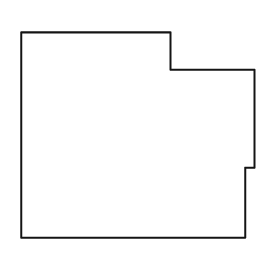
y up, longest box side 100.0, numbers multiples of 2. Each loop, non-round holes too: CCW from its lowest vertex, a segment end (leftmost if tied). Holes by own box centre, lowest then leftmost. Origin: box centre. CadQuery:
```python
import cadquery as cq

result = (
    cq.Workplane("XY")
    .moveTo(-50.0, -44.0)
    .lineTo(46.0, -44.0)
    .lineTo(46.0, -14.0)
    .lineTo(50.0, -14.0)
    .lineTo(50.0, 28.0)
    .lineTo(14.0, 28.0)
    .lineTo(14.0, 44.0)
    .lineTo(-50.0, 44.0)
    .close()
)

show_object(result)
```